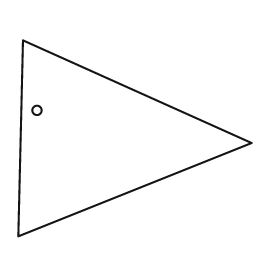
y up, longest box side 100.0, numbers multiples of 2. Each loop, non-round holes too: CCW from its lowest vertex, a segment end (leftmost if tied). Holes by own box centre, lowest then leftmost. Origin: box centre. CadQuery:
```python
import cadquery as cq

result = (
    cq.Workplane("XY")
    .moveTo(-50.0, -42.0)
    .lineTo(50.0, -2.0)
    .lineTo(-48.0, 42.0)
    .close()
    .moveTo(-42.0, 12.0)
    .circle(2.0)
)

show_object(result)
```